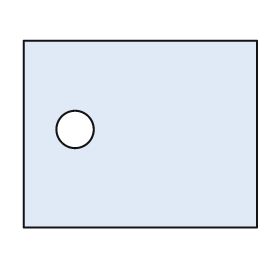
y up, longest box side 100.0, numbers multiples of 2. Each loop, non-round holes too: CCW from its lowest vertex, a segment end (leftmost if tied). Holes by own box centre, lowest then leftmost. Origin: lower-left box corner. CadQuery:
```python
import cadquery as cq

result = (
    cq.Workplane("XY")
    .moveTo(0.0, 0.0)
    .lineTo(100.0, 0.0)
    .lineTo(100.0, 80.0)
    .lineTo(0.0, 80.0)
    .close()
    .moveTo(22.0, 42.0)
    .circle(8.0)
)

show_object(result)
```